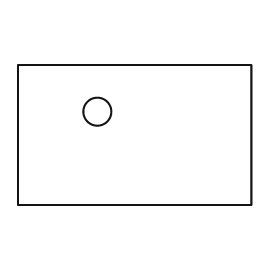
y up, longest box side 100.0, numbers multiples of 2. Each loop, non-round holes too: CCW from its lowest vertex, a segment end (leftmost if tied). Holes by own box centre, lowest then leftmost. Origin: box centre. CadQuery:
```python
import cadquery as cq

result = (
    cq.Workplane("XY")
    .moveTo(-50.0, -30.0)
    .lineTo(50.0, -30.0)
    .lineTo(50.0, 30.0)
    .lineTo(-50.0, 30.0)
    .close()
    .moveTo(-16.0, 10.0)
    .circle(6.0)
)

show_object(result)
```